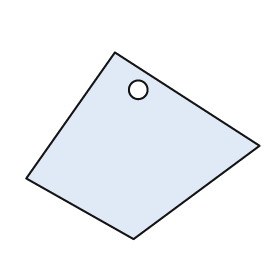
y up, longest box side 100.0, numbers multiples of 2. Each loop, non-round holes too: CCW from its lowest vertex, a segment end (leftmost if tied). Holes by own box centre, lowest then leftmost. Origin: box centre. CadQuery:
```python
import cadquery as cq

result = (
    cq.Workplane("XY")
    .moveTo(-4.0, -40.0)
    .lineTo(50.0, 0.0)
    .lineTo(-12.0, 40.0)
    .lineTo(-50.0, -14.0)
    .close()
    .moveTo(-2.0, 24.0)
    .circle(4.0)
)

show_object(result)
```